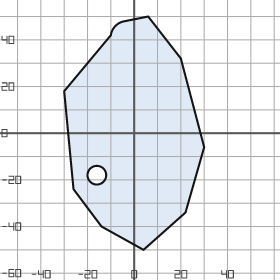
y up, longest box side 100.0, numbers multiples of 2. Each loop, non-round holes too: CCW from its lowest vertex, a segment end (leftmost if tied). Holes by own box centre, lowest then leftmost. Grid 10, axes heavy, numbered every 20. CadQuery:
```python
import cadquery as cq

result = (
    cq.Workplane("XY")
    .moveTo(4.0, -50.0)
    .lineTo(22.0, -34.0)
    .lineTo(30.0, -6.0)
    .lineTo(20.0, 32.0)
    .lineTo(6.0, 50.0)
    .lineTo(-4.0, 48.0)
    .threePointArc((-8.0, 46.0), (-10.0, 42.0))
    .lineTo(-30.0, 18.0)
    .lineTo(-26.0, -24.0)
    .lineTo(-14.0, -40.0)
    .close()
    .moveTo(-16.0, -18.0)
    .circle(4.0)
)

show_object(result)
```